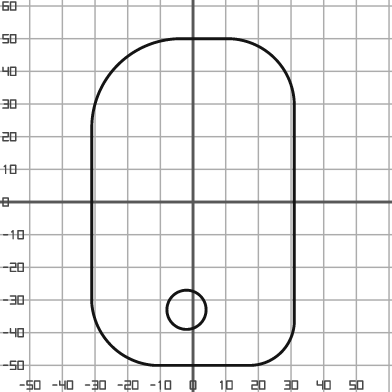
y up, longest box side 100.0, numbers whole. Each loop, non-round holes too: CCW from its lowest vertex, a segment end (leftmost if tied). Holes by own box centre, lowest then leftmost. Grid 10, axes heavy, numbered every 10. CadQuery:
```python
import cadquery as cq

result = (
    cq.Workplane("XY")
    .moveTo(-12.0, -50.0)
    .lineTo(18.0, -50.0)
    .threePointArc((27.0, -46.0), (31.0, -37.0))
    .lineTo(31.0, 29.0)
    .threePointArc((25.0, 44.0), (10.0, 50.0))
    .lineTo(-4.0, 50.0)
    .threePointArc((-23.0, 42.0), (-31.0, 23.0))
    .lineTo(-31.0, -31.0)
    .threePointArc((-25.0, -44.0), (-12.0, -50.0))
    .close()
    .moveTo(-2.0, -33.0)
    .circle(6.0)
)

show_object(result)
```